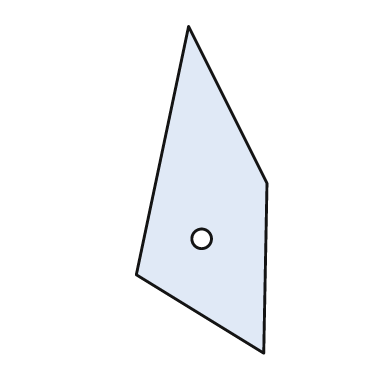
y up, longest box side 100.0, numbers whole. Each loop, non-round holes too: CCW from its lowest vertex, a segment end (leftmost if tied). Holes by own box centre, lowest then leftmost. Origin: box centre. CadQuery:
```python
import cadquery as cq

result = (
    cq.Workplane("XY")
    .moveTo(19.0, -50.0)
    .lineTo(20.0, 2.0)
    .lineTo(-4.0, 50.0)
    .lineTo(-20.0, -26.0)
    .close()
    .moveTo(0.0, -15.0)
    .circle(3.0)
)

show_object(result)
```